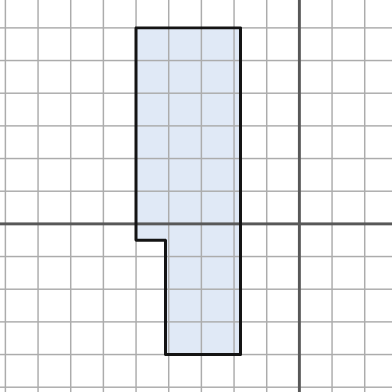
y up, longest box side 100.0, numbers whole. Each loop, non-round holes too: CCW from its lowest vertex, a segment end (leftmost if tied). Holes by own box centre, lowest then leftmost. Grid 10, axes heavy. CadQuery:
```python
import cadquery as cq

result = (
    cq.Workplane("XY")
    .moveTo(-41.0, -40.0)
    .lineTo(-18.0, -40.0)
    .lineTo(-18.0, 60.0)
    .lineTo(-50.0, 60.0)
    .lineTo(-50.0, -5.0)
    .lineTo(-41.0, -5.0)
    .close()
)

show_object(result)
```